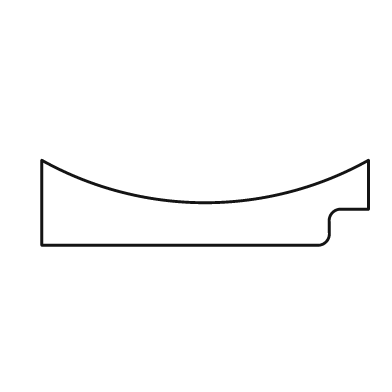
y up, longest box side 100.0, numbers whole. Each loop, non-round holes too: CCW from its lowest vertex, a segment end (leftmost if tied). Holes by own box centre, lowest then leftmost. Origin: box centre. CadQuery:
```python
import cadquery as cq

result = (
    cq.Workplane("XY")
    .moveTo(-50.0, -13.0)
    .lineTo(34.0, -13.0)
    .threePointArc((37.0, -12.0), (38.0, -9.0))
    .lineTo(38.0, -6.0)
    .threePointArc((39.0, -3.0), (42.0, -2.0))
    .lineTo(50.0, -2.0)
    .lineTo(50.0, 13.0)
    .threePointArc((0.0, 0.0), (-50.0, 13.0))
    .close()
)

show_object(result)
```